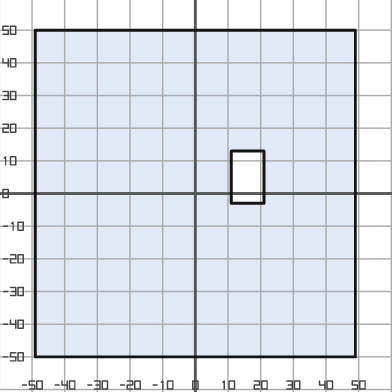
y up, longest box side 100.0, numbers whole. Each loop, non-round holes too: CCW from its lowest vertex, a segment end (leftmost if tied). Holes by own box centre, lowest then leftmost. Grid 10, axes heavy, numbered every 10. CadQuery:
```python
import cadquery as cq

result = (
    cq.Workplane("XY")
    .moveTo(-49.0, -50.0)
    .lineTo(49.0, -50.0)
    .lineTo(49.0, 50.0)
    .lineTo(-49.0, 50.0)
    .close()
    .moveTo(11.0, -3.0)
    .lineTo(21.0, -3.0)
    .lineTo(21.0, 13.0)
    .lineTo(11.0, 13.0)
    .close()
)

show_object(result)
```